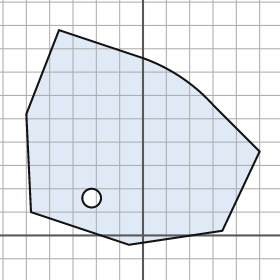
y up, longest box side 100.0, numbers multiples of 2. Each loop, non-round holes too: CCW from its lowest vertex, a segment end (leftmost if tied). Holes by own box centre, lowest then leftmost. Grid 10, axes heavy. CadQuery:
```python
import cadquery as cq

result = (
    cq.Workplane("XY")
    .moveTo(-6.0, -4.0)
    .lineTo(34.0, 2.0)
    .lineTo(50.0, 36.0)
    .lineTo(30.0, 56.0)
    .threePointArc((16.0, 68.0), (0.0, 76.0))
    .lineTo(-36.0, 88.0)
    .lineTo(-50.0, 52.0)
    .lineTo(-48.0, 10.0)
    .close()
    .moveTo(-22.0, 16.0)
    .circle(4.0)
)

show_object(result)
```